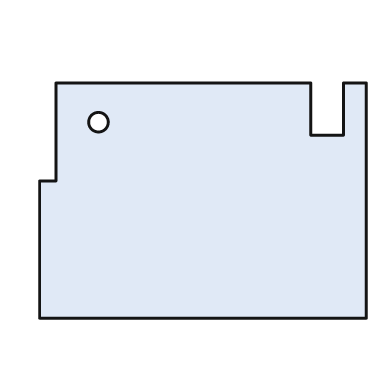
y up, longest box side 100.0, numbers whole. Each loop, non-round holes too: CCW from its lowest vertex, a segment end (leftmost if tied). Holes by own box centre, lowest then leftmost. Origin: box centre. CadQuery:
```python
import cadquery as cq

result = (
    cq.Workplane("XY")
    .moveTo(-50.0, -36.0)
    .lineTo(50.0, -36.0)
    .lineTo(50.0, 36.0)
    .lineTo(43.0, 36.0)
    .lineTo(43.0, 20.0)
    .lineTo(33.0, 20.0)
    .lineTo(33.0, 36.0)
    .lineTo(-45.0, 36.0)
    .lineTo(-45.0, 6.0)
    .lineTo(-50.0, 6.0)
    .close()
    .moveTo(-32.0, 24.0)
    .circle(3.0)
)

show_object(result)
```